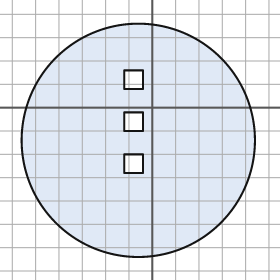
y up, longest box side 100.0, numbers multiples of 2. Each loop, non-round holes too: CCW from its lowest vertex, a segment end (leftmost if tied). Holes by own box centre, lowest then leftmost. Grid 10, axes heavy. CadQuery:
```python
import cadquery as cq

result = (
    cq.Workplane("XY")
    .moveTo(-6.0, -14.0)
    .circle(50.0)
    .moveTo(-12.0, -28.0)
    .lineTo(-4.0, -28.0)
    .lineTo(-4.0, -20.0)
    .lineTo(-12.0, -20.0)
    .close()
    .moveTo(-12.0, -10.0)
    .lineTo(-4.0, -10.0)
    .lineTo(-4.0, -2.0)
    .lineTo(-12.0, -2.0)
    .close()
    .moveTo(-12.0, 8.0)
    .lineTo(-4.0, 8.0)
    .lineTo(-4.0, 16.0)
    .lineTo(-12.0, 16.0)
    .close()
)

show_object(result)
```